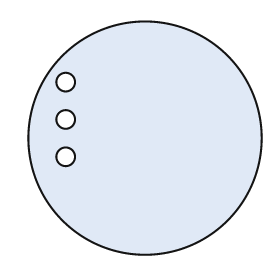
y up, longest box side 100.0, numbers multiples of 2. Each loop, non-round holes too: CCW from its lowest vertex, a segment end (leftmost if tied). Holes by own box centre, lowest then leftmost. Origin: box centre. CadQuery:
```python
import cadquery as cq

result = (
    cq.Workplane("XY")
    .moveTo(0.0, 0.0)
    .circle(50.0)
    .moveTo(-34.0, -8.0)
    .circle(4.0)
    .moveTo(-34.0, 8.0)
    .circle(4.0)
    .moveTo(-34.0, 24.0)
    .circle(4.0)
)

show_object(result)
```